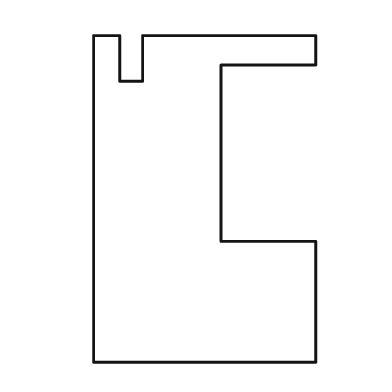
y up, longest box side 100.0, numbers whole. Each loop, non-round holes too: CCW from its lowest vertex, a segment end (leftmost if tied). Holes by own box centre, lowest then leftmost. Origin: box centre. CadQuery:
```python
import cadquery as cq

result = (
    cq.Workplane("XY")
    .moveTo(-34.0, -50.0)
    .lineTo(34.0, -50.0)
    .lineTo(34.0, -13.0)
    .lineTo(5.0, -13.0)
    .lineTo(5.0, 41.0)
    .lineTo(34.0, 41.0)
    .lineTo(34.0, 50.0)
    .lineTo(-19.0, 50.0)
    .lineTo(-19.0, 36.0)
    .lineTo(-26.0, 36.0)
    .lineTo(-26.0, 50.0)
    .lineTo(-34.0, 50.0)
    .close()
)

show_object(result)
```